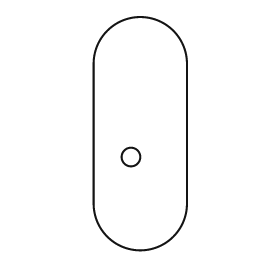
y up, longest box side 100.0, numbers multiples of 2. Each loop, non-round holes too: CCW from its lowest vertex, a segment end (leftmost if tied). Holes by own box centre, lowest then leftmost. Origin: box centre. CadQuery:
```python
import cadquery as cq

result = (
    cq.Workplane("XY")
    .moveTo(-20.0, -30.0)
    .threePointArc((0.0, -50.0), (20.0, -30.0))
    .lineTo(20.0, 30.0)
    .threePointArc((0.0, 50.0), (-20.0, 30.0))
    .close()
    .moveTo(-4.0, -10.0)
    .circle(4.0)
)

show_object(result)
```